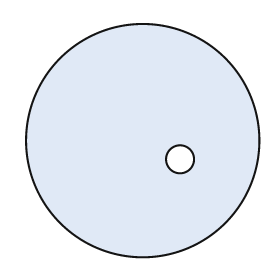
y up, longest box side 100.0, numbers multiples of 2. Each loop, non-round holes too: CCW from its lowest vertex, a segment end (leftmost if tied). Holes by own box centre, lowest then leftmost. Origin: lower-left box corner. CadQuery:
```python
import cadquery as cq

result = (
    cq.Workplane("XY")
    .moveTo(50.0, 50.0)
    .circle(50.0)
    .moveTo(66.0, 42.0)
    .circle(6.0)
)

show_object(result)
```